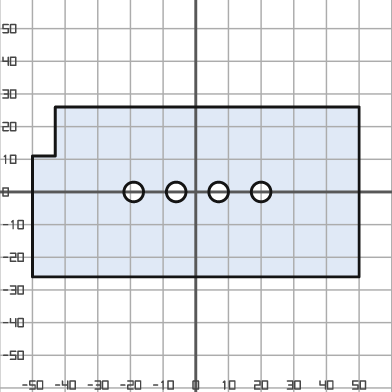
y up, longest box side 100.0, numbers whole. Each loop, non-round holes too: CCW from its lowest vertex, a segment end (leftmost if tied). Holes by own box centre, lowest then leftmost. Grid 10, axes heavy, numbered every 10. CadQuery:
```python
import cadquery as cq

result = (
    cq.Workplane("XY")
    .moveTo(-50.0, -26.0)
    .lineTo(50.0, -26.0)
    .lineTo(50.0, 26.0)
    .lineTo(-43.0, 26.0)
    .lineTo(-43.0, 11.0)
    .lineTo(-50.0, 11.0)
    .close()
    .moveTo(-19.0, 0.0)
    .circle(3.0)
    .moveTo(-6.0, 0.0)
    .circle(3.0)
    .moveTo(7.0, 0.0)
    .circle(3.0)
    .moveTo(20.0, 0.0)
    .circle(3.0)
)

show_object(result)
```